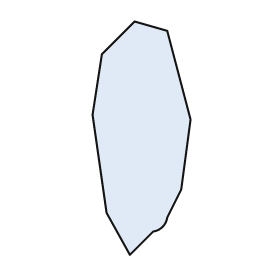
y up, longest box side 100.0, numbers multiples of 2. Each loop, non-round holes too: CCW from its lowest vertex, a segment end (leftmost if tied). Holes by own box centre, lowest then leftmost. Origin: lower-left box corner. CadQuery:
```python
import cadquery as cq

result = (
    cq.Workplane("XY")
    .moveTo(16.0, 0.0)
    .lineTo(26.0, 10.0)
    .threePointArc((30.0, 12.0), (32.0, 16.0))
    .lineTo(38.0, 28.0)
    .lineTo(42.0, 58.0)
    .lineTo(32.0, 96.0)
    .lineTo(18.0, 100.0)
    .lineTo(4.0, 86.0)
    .lineTo(0.0, 60.0)
    .lineTo(6.0, 18.0)
    .close()
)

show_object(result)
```